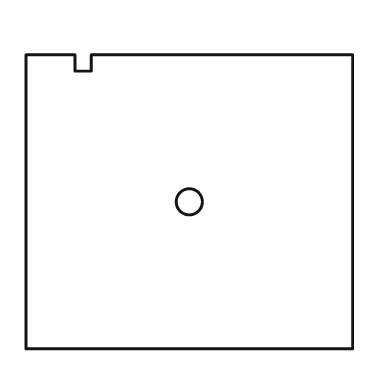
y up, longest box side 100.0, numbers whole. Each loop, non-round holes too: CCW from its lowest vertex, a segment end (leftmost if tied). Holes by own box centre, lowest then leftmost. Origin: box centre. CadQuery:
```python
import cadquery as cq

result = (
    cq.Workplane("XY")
    .moveTo(-50.0, -45.0)
    .lineTo(50.0, -45.0)
    .lineTo(50.0, 45.0)
    .lineTo(-30.0, 45.0)
    .lineTo(-30.0, 40.0)
    .lineTo(-35.0, 40.0)
    .lineTo(-35.0, 45.0)
    .lineTo(-50.0, 45.0)
    .close()
    .moveTo(0.0, 0.0)
    .circle(4.0)
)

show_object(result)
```